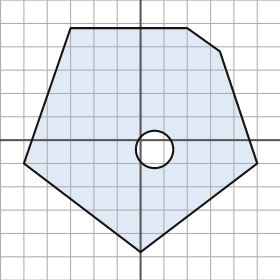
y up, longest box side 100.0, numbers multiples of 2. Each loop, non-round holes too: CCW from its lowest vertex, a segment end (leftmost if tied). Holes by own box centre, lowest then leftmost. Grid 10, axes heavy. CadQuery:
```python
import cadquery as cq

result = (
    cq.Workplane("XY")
    .moveTo(0.0, -48.0)
    .lineTo(50.0, -10.0)
    .lineTo(34.0, 38.0)
    .lineTo(20.0, 48.0)
    .lineTo(-30.0, 48.0)
    .lineTo(-50.0, -10.0)
    .close()
    .moveTo(6.0, -4.0)
    .circle(8.0)
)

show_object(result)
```